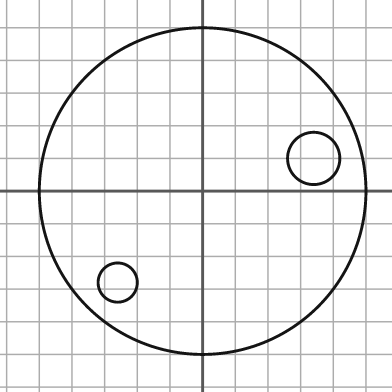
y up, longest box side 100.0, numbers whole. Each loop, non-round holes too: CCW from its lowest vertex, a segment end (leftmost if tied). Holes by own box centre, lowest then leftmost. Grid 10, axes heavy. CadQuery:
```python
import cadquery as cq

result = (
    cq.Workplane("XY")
    .moveTo(0.0, 0.0)
    .circle(50.0)
    .moveTo(-26.0, -28.0)
    .circle(6.0)
    .moveTo(34.0, 10.0)
    .circle(8.0)
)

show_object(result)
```